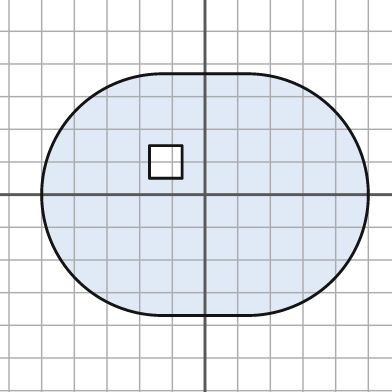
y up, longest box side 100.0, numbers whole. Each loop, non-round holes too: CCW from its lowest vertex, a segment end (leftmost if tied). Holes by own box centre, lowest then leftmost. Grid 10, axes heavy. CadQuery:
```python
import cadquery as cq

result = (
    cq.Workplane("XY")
    .moveTo(-13.0, -37.0)
    .lineTo(13.0, -37.0)
    .threePointArc((50.0, 0.0), (13.0, 37.0))
    .lineTo(-13.0, 37.0)
    .threePointArc((-50.0, 0.0), (-13.0, -37.0))
    .close()
    .moveTo(-17.0, 5.0)
    .lineTo(-7.0, 5.0)
    .lineTo(-7.0, 15.0)
    .lineTo(-17.0, 15.0)
    .close()
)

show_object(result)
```